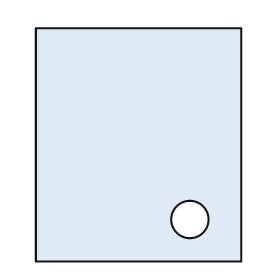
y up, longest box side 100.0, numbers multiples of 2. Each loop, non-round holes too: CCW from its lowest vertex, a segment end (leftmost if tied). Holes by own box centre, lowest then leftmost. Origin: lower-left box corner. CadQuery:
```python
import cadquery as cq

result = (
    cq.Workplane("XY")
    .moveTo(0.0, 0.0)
    .lineTo(88.0, 0.0)
    .lineTo(88.0, 100.0)
    .lineTo(0.0, 100.0)
    .close()
    .moveTo(66.0, 18.0)
    .circle(8.0)
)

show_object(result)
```